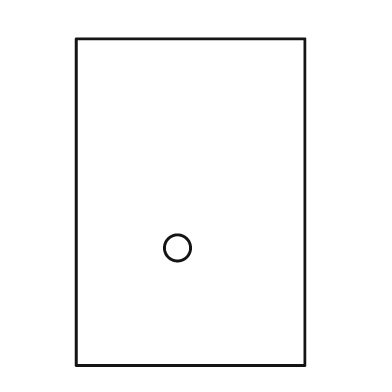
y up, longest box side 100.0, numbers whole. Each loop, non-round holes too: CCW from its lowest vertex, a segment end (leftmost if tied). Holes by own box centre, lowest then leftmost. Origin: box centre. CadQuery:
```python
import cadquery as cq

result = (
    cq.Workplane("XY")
    .moveTo(-35.0, -50.0)
    .lineTo(35.0, -50.0)
    .lineTo(35.0, 50.0)
    .lineTo(-35.0, 50.0)
    .close()
    .moveTo(-4.0, -14.0)
    .circle(4.0)
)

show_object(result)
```